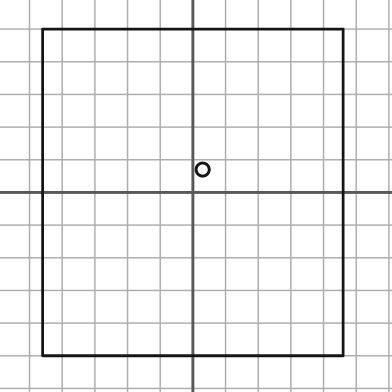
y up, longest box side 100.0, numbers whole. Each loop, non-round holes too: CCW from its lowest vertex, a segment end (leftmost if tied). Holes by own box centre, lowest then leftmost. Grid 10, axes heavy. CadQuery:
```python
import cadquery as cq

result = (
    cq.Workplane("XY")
    .moveTo(-46.0, -50.0)
    .lineTo(46.0, -50.0)
    .lineTo(46.0, 50.0)
    .lineTo(-46.0, 50.0)
    .close()
    .moveTo(3.0, 7.0)
    .circle(2.0)
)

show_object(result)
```